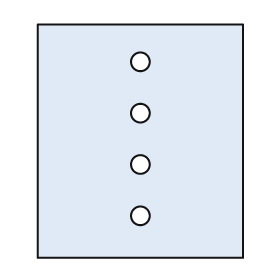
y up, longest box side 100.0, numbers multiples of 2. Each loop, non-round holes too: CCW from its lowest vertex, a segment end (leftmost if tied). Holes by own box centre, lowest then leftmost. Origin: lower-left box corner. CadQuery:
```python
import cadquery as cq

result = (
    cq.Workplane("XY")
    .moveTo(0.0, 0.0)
    .lineTo(88.0, 0.0)
    .lineTo(88.0, 100.0)
    .lineTo(0.0, 100.0)
    .close()
    .moveTo(44.0, 18.0)
    .circle(4.0)
    .moveTo(44.0, 40.0)
    .circle(4.0)
    .moveTo(44.0, 62.0)
    .circle(4.0)
    .moveTo(44.0, 84.0)
    .circle(4.0)
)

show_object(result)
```